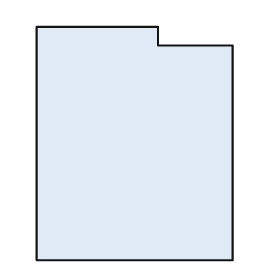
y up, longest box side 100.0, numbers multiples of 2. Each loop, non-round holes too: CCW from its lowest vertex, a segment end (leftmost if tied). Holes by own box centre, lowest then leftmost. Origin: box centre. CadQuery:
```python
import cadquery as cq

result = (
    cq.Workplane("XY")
    .moveTo(-42.0, -50.0)
    .lineTo(42.0, -50.0)
    .lineTo(42.0, 42.0)
    .lineTo(10.0, 42.0)
    .lineTo(10.0, 50.0)
    .lineTo(-42.0, 50.0)
    .close()
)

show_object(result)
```